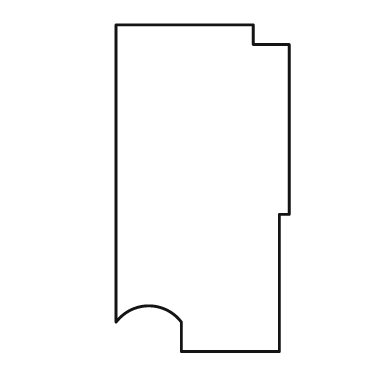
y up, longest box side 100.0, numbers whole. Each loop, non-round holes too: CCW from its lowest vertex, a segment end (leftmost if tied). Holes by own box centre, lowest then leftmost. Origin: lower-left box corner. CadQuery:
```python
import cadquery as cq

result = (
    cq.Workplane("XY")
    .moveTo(20.0, 0.0)
    .lineTo(50.0, 0.0)
    .lineTo(50.0, 42.0)
    .lineTo(53.0, 42.0)
    .lineTo(53.0, 94.0)
    .lineTo(42.0, 94.0)
    .lineTo(42.0, 100.0)
    .lineTo(0.0, 100.0)
    .lineTo(0.0, 9.0)
    .threePointArc((10.0, 14.0), (20.0, 9.0))
    .close()
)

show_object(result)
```